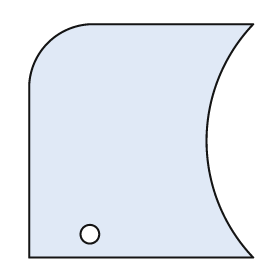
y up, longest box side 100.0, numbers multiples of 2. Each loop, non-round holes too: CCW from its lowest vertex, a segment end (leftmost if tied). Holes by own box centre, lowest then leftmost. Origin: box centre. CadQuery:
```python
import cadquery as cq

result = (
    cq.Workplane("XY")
    .moveTo(-48.0, -50.0)
    .lineTo(48.0, -50.0)
    .threePointArc((28.0, 0.0), (48.0, 50.0))
    .lineTo(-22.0, 50.0)
    .threePointArc((-40.0, 42.0), (-48.0, 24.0))
    .close()
    .moveTo(-22.0, -40.0)
    .circle(4.0)
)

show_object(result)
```